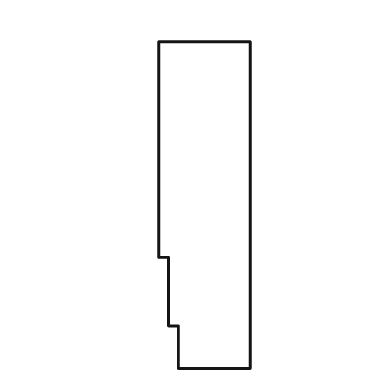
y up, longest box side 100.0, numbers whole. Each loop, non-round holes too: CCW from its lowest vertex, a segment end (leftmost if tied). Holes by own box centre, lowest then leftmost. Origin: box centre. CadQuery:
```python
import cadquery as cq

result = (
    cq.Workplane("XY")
    .moveTo(-8.0, -50.0)
    .lineTo(14.0, -50.0)
    .lineTo(14.0, 50.0)
    .lineTo(-14.0, 50.0)
    .lineTo(-14.0, -16.0)
    .lineTo(-11.0, -16.0)
    .lineTo(-11.0, -37.0)
    .lineTo(-8.0, -37.0)
    .close()
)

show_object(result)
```